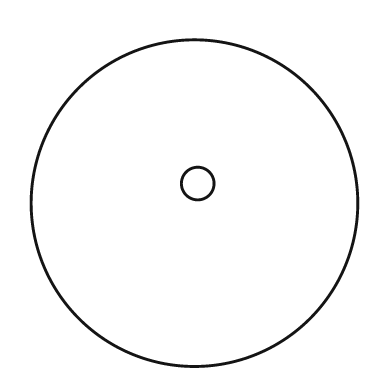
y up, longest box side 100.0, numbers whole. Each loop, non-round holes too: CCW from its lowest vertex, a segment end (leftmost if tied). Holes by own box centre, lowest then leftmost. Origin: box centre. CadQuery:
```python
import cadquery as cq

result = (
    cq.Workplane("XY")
    .moveTo(0.0, 0.0)
    .circle(50.0)
    .moveTo(1.0, 6.0)
    .circle(5.0)
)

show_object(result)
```